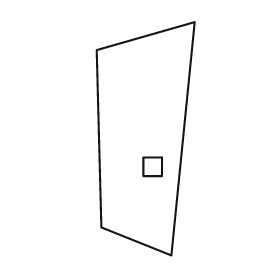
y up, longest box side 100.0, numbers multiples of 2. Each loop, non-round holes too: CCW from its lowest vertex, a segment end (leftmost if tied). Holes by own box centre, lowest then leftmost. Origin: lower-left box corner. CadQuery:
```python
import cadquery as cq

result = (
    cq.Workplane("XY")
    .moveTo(32.0, 0.0)
    .lineTo(42.0, 100.0)
    .lineTo(0.0, 88.0)
    .lineTo(2.0, 12.0)
    .close()
    .moveTo(20.0, 34.0)
    .lineTo(28.0, 34.0)
    .lineTo(28.0, 42.0)
    .lineTo(20.0, 42.0)
    .close()
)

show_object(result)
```